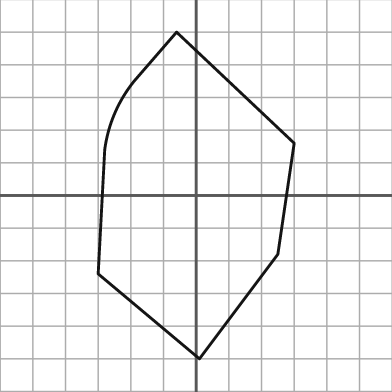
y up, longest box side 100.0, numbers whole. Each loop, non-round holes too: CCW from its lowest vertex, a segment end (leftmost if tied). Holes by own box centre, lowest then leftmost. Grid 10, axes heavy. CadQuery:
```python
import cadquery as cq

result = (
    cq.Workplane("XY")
    .moveTo(1.0, -50.0)
    .lineTo(25.0, -18.0)
    .lineTo(30.0, 16.0)
    .lineTo(-6.0, 50.0)
    .lineTo(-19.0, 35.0)
    .threePointArc((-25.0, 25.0), (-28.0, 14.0))
    .lineTo(-30.0, -24.0)
    .close()
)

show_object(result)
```